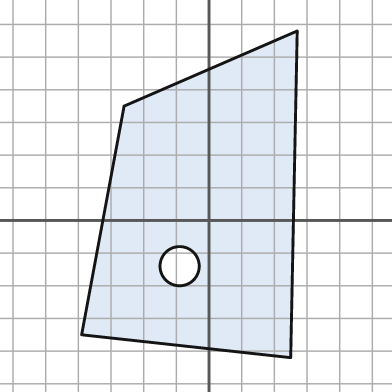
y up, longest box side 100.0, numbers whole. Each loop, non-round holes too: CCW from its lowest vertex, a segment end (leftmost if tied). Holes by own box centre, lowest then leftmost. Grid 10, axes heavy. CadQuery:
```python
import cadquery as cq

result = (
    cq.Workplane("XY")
    .moveTo(25.0, -42.0)
    .lineTo(27.0, 58.0)
    .lineTo(-26.0, 35.0)
    .lineTo(-39.0, -35.0)
    .close()
    .moveTo(-9.0, -14.0)
    .circle(6.0)
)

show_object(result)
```